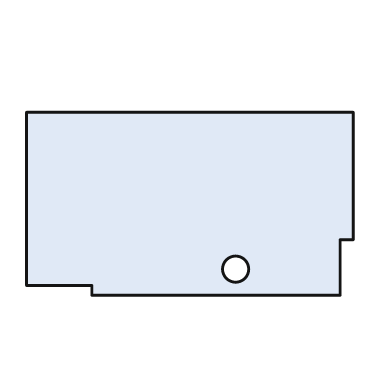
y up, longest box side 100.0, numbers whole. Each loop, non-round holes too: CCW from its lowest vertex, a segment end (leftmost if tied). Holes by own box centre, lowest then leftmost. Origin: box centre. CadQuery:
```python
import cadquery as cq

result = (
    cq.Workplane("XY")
    .moveTo(-30.0, -28.0)
    .lineTo(46.0, -28.0)
    .lineTo(46.0, -11.0)
    .lineTo(50.0, -11.0)
    .lineTo(50.0, 28.0)
    .lineTo(-50.0, 28.0)
    .lineTo(-50.0, -25.0)
    .lineTo(-30.0, -25.0)
    .close()
    .moveTo(14.0, -20.0)
    .circle(4.0)
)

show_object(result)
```